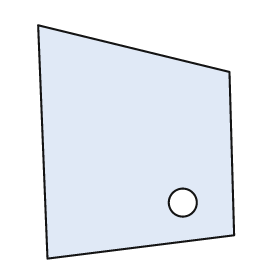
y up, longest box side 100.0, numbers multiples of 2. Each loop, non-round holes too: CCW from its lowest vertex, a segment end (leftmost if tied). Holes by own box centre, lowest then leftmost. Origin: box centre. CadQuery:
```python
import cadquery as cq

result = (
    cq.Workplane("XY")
    .moveTo(-38.0, -50.0)
    .lineTo(42.0, -40.0)
    .lineTo(40.0, 30.0)
    .lineTo(-42.0, 50.0)
    .close()
    .moveTo(20.0, -26.0)
    .circle(6.0)
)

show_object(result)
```